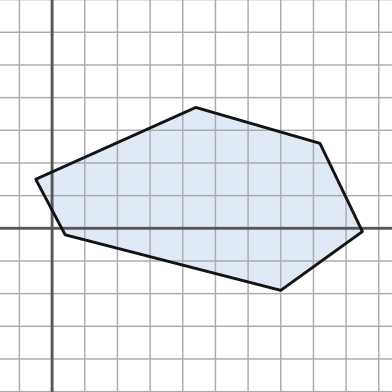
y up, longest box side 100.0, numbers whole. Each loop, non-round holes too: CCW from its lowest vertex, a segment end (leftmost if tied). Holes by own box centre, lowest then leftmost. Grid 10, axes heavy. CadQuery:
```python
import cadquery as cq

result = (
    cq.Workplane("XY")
    .moveTo(70.0, -19.0)
    .lineTo(95.0, -1.0)
    .lineTo(82.0, 26.0)
    .lineTo(44.0, 37.0)
    .lineTo(-5.0, 15.0)
    .lineTo(4.0, -2.0)
    .close()
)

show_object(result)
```